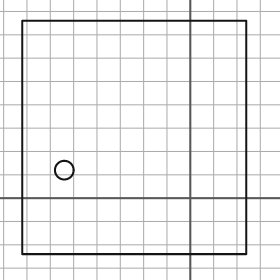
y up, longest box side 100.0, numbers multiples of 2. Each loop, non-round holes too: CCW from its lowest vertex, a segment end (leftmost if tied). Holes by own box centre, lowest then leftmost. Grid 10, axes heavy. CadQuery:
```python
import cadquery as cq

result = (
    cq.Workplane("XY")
    .moveTo(-72.0, -24.0)
    .lineTo(24.0, -24.0)
    .lineTo(24.0, 76.0)
    .lineTo(-72.0, 76.0)
    .close()
    .moveTo(-54.0, 12.0)
    .circle(4.0)
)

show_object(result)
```